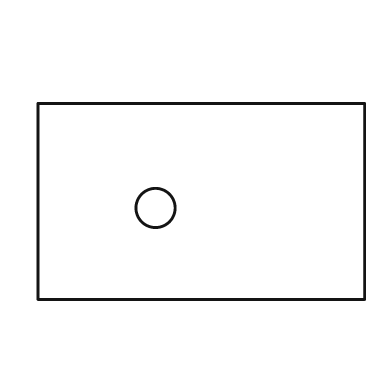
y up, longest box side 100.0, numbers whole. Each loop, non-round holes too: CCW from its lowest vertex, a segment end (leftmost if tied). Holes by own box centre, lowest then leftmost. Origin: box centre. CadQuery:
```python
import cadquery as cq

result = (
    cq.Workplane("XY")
    .moveTo(-50.0, -30.0)
    .lineTo(50.0, -30.0)
    .lineTo(50.0, 30.0)
    .lineTo(-50.0, 30.0)
    .close()
    .moveTo(-14.0, -2.0)
    .circle(6.0)
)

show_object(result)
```